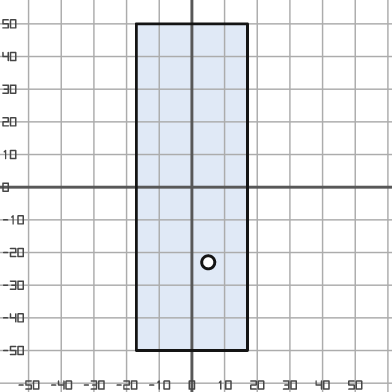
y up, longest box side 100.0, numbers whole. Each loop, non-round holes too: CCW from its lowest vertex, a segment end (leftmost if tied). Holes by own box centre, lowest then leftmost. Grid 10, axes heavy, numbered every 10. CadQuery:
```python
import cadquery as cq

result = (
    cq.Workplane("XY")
    .moveTo(-17.0, -50.0)
    .lineTo(17.0, -50.0)
    .lineTo(17.0, 50.0)
    .lineTo(-17.0, 50.0)
    .close()
    .moveTo(5.0, -23.0)
    .circle(2.0)
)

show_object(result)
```